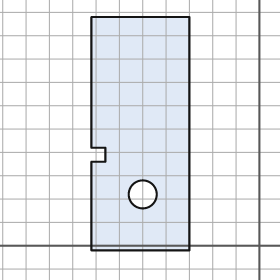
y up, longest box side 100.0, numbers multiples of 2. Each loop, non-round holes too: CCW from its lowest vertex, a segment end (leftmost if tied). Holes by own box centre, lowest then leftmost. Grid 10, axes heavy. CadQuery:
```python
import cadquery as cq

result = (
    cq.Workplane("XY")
    .moveTo(-72.0, -2.0)
    .lineTo(-30.0, -2.0)
    .lineTo(-30.0, 98.0)
    .lineTo(-72.0, 98.0)
    .lineTo(-72.0, 42.0)
    .lineTo(-66.0, 42.0)
    .lineTo(-66.0, 36.0)
    .lineTo(-72.0, 36.0)
    .close()
    .moveTo(-50.0, 22.0)
    .circle(6.0)
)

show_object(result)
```